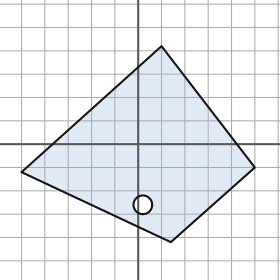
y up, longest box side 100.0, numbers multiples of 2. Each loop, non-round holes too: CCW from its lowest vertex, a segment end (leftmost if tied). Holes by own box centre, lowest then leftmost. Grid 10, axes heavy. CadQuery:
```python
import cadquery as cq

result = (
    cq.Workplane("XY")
    .moveTo(14.0, -42.0)
    .lineTo(50.0, -10.0)
    .lineTo(10.0, 42.0)
    .lineTo(-50.0, -12.0)
    .close()
    .moveTo(2.0, -26.0)
    .circle(4.0)
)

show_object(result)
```